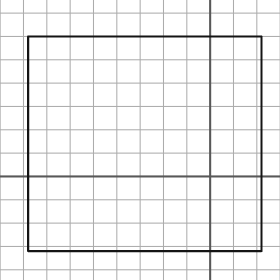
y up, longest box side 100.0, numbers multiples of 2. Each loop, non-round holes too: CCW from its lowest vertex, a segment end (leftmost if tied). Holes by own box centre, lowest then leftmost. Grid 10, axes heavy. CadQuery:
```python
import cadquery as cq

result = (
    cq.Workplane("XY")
    .moveTo(-78.0, -32.0)
    .lineTo(22.0, -32.0)
    .lineTo(22.0, 60.0)
    .lineTo(-78.0, 60.0)
    .close()
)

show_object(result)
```